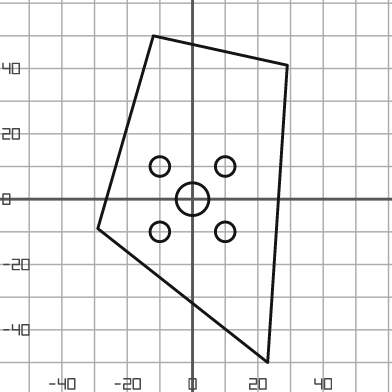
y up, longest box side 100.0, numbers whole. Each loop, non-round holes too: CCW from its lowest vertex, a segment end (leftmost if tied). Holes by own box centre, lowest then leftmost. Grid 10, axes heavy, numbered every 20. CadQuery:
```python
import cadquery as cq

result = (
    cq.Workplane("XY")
    .moveTo(23.0, -50.0)
    .lineTo(29.0, 41.0)
    .lineTo(-12.0, 50.0)
    .lineTo(-29.0, -9.0)
    .close()
    .moveTo(-10.0, -10.0)
    .circle(3.0)
    .moveTo(10.0, -10.0)
    .circle(3.0)
    .moveTo(0.0, 0.0)
    .circle(5.0)
    .moveTo(-10.0, 10.0)
    .circle(3.0)
    .moveTo(10.0, 10.0)
    .circle(3.0)
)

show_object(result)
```